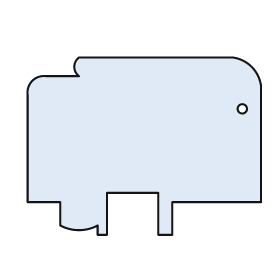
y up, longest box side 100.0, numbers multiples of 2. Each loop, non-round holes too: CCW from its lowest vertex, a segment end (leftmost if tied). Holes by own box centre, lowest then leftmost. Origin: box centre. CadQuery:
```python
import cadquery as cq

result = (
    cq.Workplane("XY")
    .moveTo(-20.0, -38.0)
    .lineTo(-16.0, -38.0)
    .lineTo(-16.0, -20.0)
    .lineTo(6.0, -20.0)
    .lineTo(6.0, -38.0)
    .lineTo(12.0, -38.0)
    .lineTo(12.0, -24.0)
    .lineTo(50.0, -24.0)
    .lineTo(50.0, 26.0)
    .threePointArc((46.0, 34.0), (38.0, 38.0))
    .lineTo(-28.0, 38.0)
    .threePointArc((-30.0, 34.0), (-28.0, 30.0))
    .lineTo(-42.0, 30.0)
    .threePointArc((-48.0, 28.0), (-50.0, 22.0))
    .lineTo(-50.0, -24.0)
    .lineTo(-36.0, -24.0)
    .lineTo(-36.0, -34.0)
    .threePointArc((-28.0, -36.0), (-20.0, -34.0))
    .close()
    .moveTo(42.0, 16.0)
    .circle(2.0)
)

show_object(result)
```